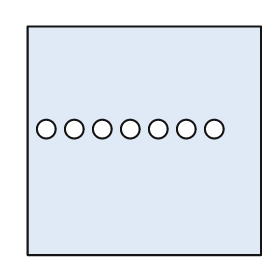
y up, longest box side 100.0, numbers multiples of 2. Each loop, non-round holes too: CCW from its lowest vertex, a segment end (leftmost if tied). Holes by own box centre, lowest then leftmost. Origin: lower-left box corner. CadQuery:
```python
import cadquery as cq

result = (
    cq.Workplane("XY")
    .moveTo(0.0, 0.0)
    .lineTo(100.0, 0.0)
    .lineTo(100.0, 98.0)
    .lineTo(0.0, 98.0)
    .close()
    .moveTo(8.0, 54.0)
    .circle(4.0)
    .moveTo(20.0, 54.0)
    .circle(4.0)
    .moveTo(32.0, 54.0)
    .circle(4.0)
    .moveTo(44.0, 54.0)
    .circle(4.0)
    .moveTo(56.0, 54.0)
    .circle(4.0)
    .moveTo(68.0, 54.0)
    .circle(4.0)
    .moveTo(80.0, 54.0)
    .circle(4.0)
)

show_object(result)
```